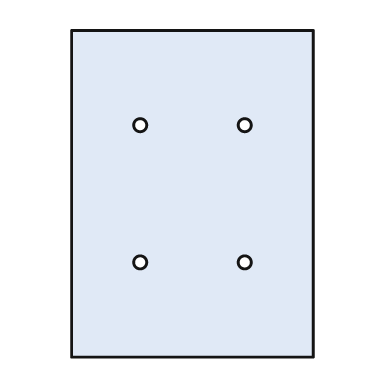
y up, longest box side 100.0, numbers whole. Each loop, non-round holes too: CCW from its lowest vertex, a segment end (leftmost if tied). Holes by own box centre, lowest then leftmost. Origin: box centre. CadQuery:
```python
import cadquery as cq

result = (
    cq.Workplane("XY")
    .moveTo(-37.0, -50.0)
    .lineTo(37.0, -50.0)
    .lineTo(37.0, 50.0)
    .lineTo(-37.0, 50.0)
    .close()
    .moveTo(-16.0, -21.0)
    .circle(2.0)
    .moveTo(16.0, -21.0)
    .circle(2.0)
    .moveTo(-16.0, 21.0)
    .circle(2.0)
    .moveTo(16.0, 21.0)
    .circle(2.0)
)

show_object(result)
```